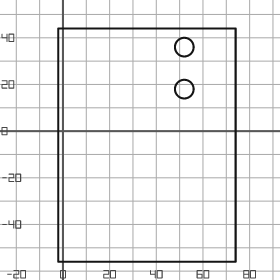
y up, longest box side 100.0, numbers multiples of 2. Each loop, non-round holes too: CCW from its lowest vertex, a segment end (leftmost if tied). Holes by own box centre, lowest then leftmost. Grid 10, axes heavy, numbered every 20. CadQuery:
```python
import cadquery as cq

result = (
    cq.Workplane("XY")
    .moveTo(-2.0, -56.0)
    .lineTo(74.0, -56.0)
    .lineTo(74.0, 44.0)
    .lineTo(-2.0, 44.0)
    .close()
    .moveTo(52.0, 18.0)
    .circle(4.0)
    .moveTo(52.0, 36.0)
    .circle(4.0)
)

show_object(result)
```